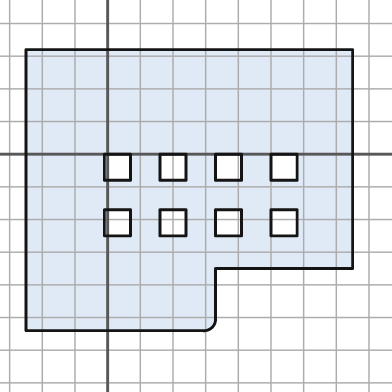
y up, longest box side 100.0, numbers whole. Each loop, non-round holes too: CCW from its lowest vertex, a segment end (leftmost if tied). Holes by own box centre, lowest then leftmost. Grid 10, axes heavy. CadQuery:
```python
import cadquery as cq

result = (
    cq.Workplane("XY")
    .moveTo(-25.0, -54.0)
    .lineTo(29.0, -54.0)
    .threePointArc((32.0, -53.0), (33.0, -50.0))
    .lineTo(33.0, -35.0)
    .lineTo(75.0, -35.0)
    .lineTo(75.0, 32.0)
    .lineTo(-25.0, 32.0)
    .close()
    .moveTo(-1.0, -25.0)
    .lineTo(7.0, -25.0)
    .lineTo(7.0, -17.0)
    .lineTo(-1.0, -17.0)
    .close()
    .moveTo(16.0, -25.0)
    .lineTo(24.0, -25.0)
    .lineTo(24.0, -17.0)
    .lineTo(16.0, -17.0)
    .close()
    .moveTo(33.0, -25.0)
    .lineTo(41.0, -25.0)
    .lineTo(41.0, -17.0)
    .lineTo(33.0, -17.0)
    .close()
    .moveTo(50.0, -25.0)
    .lineTo(58.0, -25.0)
    .lineTo(58.0, -17.0)
    .lineTo(50.0, -17.0)
    .close()
    .moveTo(-1.0, -8.0)
    .lineTo(7.0, -8.0)
    .lineTo(7.0, 0.0)
    .lineTo(-1.0, 0.0)
    .close()
    .moveTo(16.0, -8.0)
    .lineTo(24.0, -8.0)
    .lineTo(24.0, 0.0)
    .lineTo(16.0, 0.0)
    .close()
    .moveTo(33.0, -8.0)
    .lineTo(41.0, -8.0)
    .lineTo(41.0, 0.0)
    .lineTo(33.0, 0.0)
    .close()
    .moveTo(50.0, -8.0)
    .lineTo(58.0, -8.0)
    .lineTo(58.0, 0.0)
    .lineTo(50.0, 0.0)
    .close()
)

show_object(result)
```